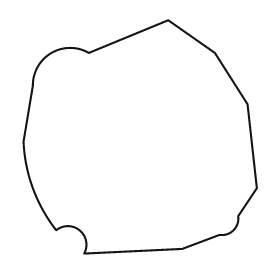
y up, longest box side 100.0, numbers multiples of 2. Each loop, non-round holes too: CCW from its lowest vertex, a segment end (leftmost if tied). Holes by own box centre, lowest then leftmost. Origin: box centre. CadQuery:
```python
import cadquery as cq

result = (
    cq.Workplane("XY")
    .moveTo(-24.0, -50.0)
    .lineTo(18.0, -48.0)
    .lineTo(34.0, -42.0)
    .threePointArc((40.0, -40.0), (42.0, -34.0))
    .lineTo(50.0, -22.0)
    .lineTo(46.0, 14.0)
    .lineTo(32.0, 36.0)
    .lineTo(12.0, 50.0)
    .lineTo(-22.0, 36.0)
    .threePointArc((-38.0, 36.0), (-46.0, 22.0))
    .lineTo(-50.0, -2.0)
    .threePointArc((-46.0, -22.0), (-36.0, -40.0))
    .threePointArc((-26.0, -40.0), (-24.0, -50.0))
    .close()
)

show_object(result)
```